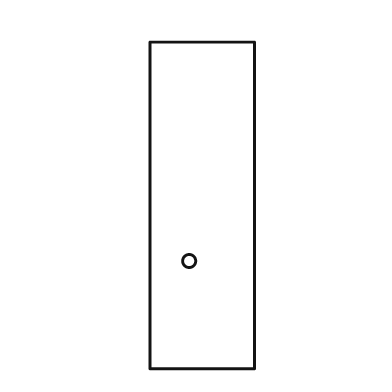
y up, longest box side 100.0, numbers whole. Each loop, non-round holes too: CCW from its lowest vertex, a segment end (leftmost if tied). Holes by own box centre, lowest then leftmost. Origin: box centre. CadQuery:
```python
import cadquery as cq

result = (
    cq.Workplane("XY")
    .moveTo(-16.0, -50.0)
    .lineTo(16.0, -50.0)
    .lineTo(16.0, 50.0)
    .lineTo(-16.0, 50.0)
    .close()
    .moveTo(-4.0, -17.0)
    .circle(2.0)
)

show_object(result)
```